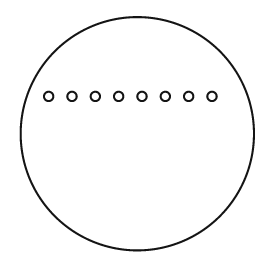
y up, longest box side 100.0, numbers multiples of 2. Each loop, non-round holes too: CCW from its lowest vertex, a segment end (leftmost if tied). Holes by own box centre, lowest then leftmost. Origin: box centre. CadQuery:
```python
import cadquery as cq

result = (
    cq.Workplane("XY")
    .moveTo(0.0, 0.0)
    .circle(50.0)
    .moveTo(-38.0, 16.0)
    .circle(2.0)
    .moveTo(-28.0, 16.0)
    .circle(2.0)
    .moveTo(-18.0, 16.0)
    .circle(2.0)
    .moveTo(-8.0, 16.0)
    .circle(2.0)
    .moveTo(2.0, 16.0)
    .circle(2.0)
    .moveTo(12.0, 16.0)
    .circle(2.0)
    .moveTo(22.0, 16.0)
    .circle(2.0)
    .moveTo(32.0, 16.0)
    .circle(2.0)
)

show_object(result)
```